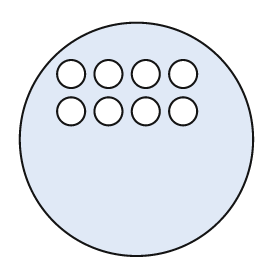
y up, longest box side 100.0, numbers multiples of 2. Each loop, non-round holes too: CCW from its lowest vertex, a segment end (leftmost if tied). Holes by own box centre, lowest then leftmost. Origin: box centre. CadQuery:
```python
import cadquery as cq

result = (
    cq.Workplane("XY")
    .moveTo(0.0, 0.0)
    .circle(50.0)
    .moveTo(-28.0, 12.0)
    .circle(6.0)
    .moveTo(-12.0, 12.0)
    .circle(6.0)
    .moveTo(4.0, 12.0)
    .circle(6.0)
    .moveTo(20.0, 12.0)
    .circle(6.0)
    .moveTo(-28.0, 28.0)
    .circle(6.0)
    .moveTo(-12.0, 28.0)
    .circle(6.0)
    .moveTo(4.0, 28.0)
    .circle(6.0)
    .moveTo(20.0, 28.0)
    .circle(6.0)
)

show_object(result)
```